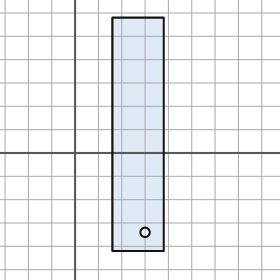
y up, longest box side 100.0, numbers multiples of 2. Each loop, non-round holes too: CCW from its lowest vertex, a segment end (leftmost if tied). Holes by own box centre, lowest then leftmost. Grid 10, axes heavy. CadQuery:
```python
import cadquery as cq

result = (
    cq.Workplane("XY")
    .moveTo(16.0, -42.0)
    .lineTo(38.0, -42.0)
    .lineTo(38.0, 58.0)
    .lineTo(16.0, 58.0)
    .close()
    .moveTo(30.0, -34.0)
    .circle(2.0)
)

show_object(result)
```